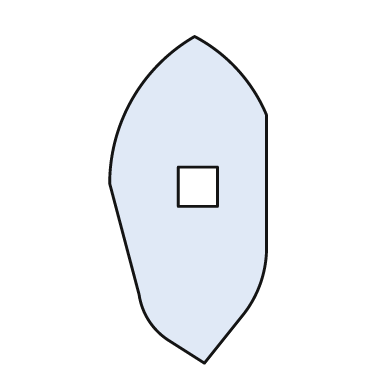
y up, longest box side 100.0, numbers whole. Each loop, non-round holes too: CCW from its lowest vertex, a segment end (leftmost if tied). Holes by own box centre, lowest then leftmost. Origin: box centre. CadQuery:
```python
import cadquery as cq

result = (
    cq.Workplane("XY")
    .moveTo(5.0, -50.0)
    .lineTo(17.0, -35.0)
    .threePointArc((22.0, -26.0), (24.0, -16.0))
    .lineTo(24.0, 26.0)
    .threePointArc((15.0, 40.0), (2.0, 50.0))
    .threePointArc((-17.0, 31.0), (-24.0, 5.0))
    .lineTo(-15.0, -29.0)
    .threePointArc((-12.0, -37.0), (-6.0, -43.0))
    .close()
    .moveTo(-3.0, -2.0)
    .lineTo(9.0, -2.0)
    .lineTo(9.0, 10.0)
    .lineTo(-3.0, 10.0)
    .close()
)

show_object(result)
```